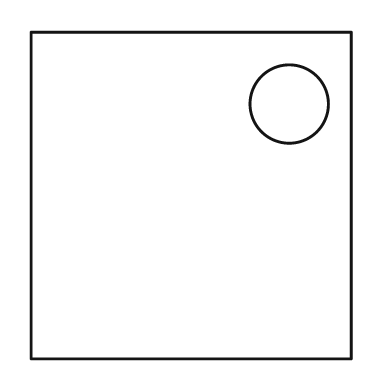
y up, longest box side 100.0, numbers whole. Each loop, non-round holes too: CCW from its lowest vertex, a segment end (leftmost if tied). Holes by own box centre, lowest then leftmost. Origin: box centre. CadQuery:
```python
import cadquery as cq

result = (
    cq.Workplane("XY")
    .moveTo(-49.0, -50.0)
    .lineTo(49.0, -50.0)
    .lineTo(49.0, 50.0)
    .lineTo(-49.0, 50.0)
    .close()
    .moveTo(30.0, 28.0)
    .circle(12.0)
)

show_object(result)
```